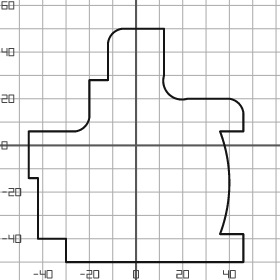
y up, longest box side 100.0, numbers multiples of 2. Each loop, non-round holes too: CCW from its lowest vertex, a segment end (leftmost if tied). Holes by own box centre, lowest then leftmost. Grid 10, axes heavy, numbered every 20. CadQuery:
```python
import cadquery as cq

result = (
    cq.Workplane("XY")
    .moveTo(-30.0, -50.0)
    .lineTo(46.0, -50.0)
    .lineTo(46.0, -38.0)
    .lineTo(36.0, -38.0)
    .threePointArc((40.0, -16.0), (36.0, 6.0))
    .lineTo(46.0, 6.0)
    .lineTo(46.0, 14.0)
    .threePointArc((44.0, 18.0), (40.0, 20.0))
    .lineTo(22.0, 20.0)
    .threePointArc((14.0, 22.0), (12.0, 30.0))
    .lineTo(12.0, 50.0)
    .lineTo(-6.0, 50.0)
    .threePointArc((-10.0, 48.0), (-12.0, 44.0))
    .lineTo(-12.0, 28.0)
    .lineTo(-20.0, 28.0)
    .lineTo(-20.0, 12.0)
    .threePointArc((-22.0, 8.0), (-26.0, 6.0))
    .lineTo(-46.0, 6.0)
    .lineTo(-46.0, -14.0)
    .lineTo(-42.0, -14.0)
    .lineTo(-42.0, -40.0)
    .lineTo(-30.0, -40.0)
    .close()
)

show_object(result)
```